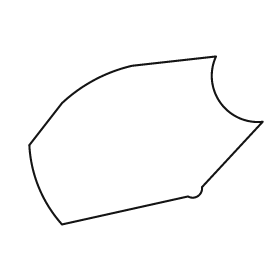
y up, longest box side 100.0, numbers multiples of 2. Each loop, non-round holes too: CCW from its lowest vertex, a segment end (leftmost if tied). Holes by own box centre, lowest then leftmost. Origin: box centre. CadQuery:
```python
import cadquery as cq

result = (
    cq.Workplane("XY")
    .moveTo(-36.0, -36.0)
    .lineTo(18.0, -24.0)
    .threePointArc((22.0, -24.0), (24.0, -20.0))
    .lineTo(50.0, 8.0)
    .threePointArc((32.0, 16.0), (30.0, 36.0))
    .lineTo(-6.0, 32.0)
    .threePointArc((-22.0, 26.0), (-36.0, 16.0))
    .lineTo(-50.0, -2.0)
    .threePointArc((-46.0, -20.0), (-36.0, -36.0))
    .close()
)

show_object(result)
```